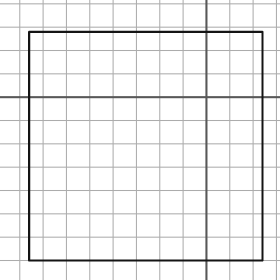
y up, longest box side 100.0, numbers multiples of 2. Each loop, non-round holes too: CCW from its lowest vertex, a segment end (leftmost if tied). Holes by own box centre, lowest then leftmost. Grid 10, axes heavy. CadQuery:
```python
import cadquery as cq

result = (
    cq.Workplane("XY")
    .moveTo(-76.0, -70.0)
    .lineTo(24.0, -70.0)
    .lineTo(24.0, 28.0)
    .lineTo(-76.0, 28.0)
    .close()
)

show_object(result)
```